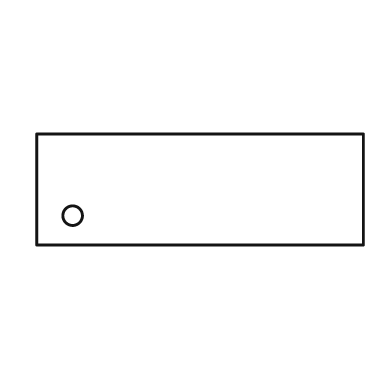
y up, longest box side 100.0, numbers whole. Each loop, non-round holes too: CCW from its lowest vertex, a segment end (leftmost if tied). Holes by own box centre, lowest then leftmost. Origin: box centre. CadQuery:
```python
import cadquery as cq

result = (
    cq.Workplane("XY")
    .moveTo(-50.0, -17.0)
    .lineTo(50.0, -17.0)
    .lineTo(50.0, 17.0)
    .lineTo(-50.0, 17.0)
    .close()
    .moveTo(-39.0, -8.0)
    .circle(3.0)
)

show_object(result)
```